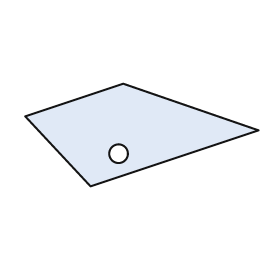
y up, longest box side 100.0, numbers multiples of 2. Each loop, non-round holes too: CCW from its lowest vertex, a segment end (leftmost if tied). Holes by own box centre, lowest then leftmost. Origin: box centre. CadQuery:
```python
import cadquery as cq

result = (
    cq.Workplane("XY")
    .moveTo(-22.0, -22.0)
    .lineTo(50.0, 2.0)
    .lineTo(-8.0, 22.0)
    .lineTo(-50.0, 8.0)
    .close()
    .moveTo(-10.0, -8.0)
    .circle(4.0)
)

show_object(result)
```